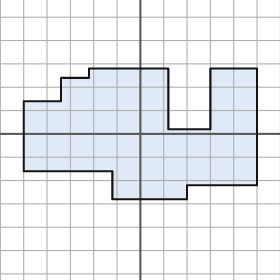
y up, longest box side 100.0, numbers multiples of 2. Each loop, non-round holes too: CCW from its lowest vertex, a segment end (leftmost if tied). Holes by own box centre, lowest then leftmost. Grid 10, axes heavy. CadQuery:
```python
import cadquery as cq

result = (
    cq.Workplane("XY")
    .moveTo(-12.0, -28.0)
    .lineTo(20.0, -28.0)
    .lineTo(20.0, -22.0)
    .lineTo(50.0, -22.0)
    .lineTo(50.0, 28.0)
    .lineTo(30.0, 28.0)
    .lineTo(30.0, 2.0)
    .lineTo(12.0, 2.0)
    .lineTo(12.0, 28.0)
    .lineTo(-22.0, 28.0)
    .lineTo(-22.0, 24.0)
    .lineTo(-34.0, 24.0)
    .lineTo(-34.0, 14.0)
    .lineTo(-50.0, 14.0)
    .lineTo(-50.0, -16.0)
    .lineTo(-12.0, -16.0)
    .close()
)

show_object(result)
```